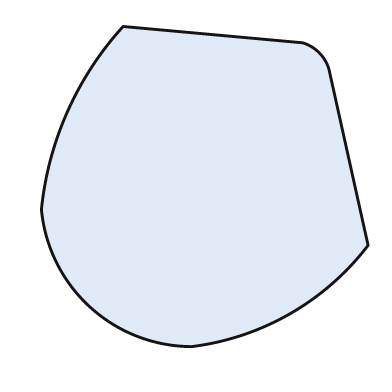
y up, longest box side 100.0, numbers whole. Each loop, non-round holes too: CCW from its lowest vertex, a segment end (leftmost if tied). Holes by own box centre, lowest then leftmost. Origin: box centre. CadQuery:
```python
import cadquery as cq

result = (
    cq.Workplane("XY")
    .moveTo(-4.0, -49.0)
    .threePointArc((26.0, -39.0), (50.0, -18.0))
    .lineTo(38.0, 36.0)
    .threePointArc((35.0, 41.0), (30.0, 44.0))
    .lineTo(-25.0, 49.0)
    .threePointArc((-42.0, 23.0), (-50.0, -7.0))
    .threePointArc((-35.0, -37.0), (-4.0, -49.0))
    .close()
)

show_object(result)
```